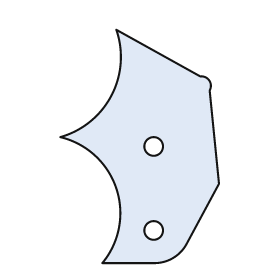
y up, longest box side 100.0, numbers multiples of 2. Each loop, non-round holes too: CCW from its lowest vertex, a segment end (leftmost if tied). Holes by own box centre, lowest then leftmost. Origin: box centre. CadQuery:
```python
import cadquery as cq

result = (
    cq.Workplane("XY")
    .moveTo(-16.0, -50.0)
    .lineTo(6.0, -50.0)
    .threePointArc((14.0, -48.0), (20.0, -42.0))
    .lineTo(34.0, -16.0)
    .lineTo(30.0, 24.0)
    .threePointArc((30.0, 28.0), (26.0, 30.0))
    .lineTo(-10.0, 50.0)
    .threePointArc((-12.0, 22.0), (-34.0, 4.0))
    .threePointArc((-10.0, -18.0), (-16.0, -50.0))
    .close()
    .moveTo(6.0, -36.0)
    .circle(4.0)
    .moveTo(6.0, 0.0)
    .circle(4.0)
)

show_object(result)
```